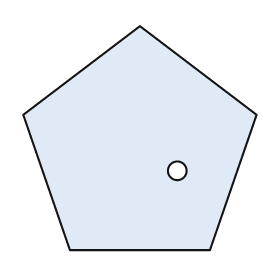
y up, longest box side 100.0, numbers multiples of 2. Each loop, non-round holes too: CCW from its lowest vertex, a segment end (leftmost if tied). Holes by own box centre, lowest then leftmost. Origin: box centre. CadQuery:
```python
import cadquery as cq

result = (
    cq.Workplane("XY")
    .moveTo(-30.0, -48.0)
    .lineTo(30.0, -48.0)
    .lineTo(50.0, 10.0)
    .lineTo(0.0, 48.0)
    .lineTo(-50.0, 10.0)
    .close()
    .moveTo(16.0, -14.0)
    .circle(4.0)
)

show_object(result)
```